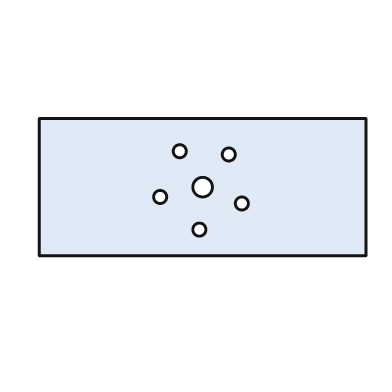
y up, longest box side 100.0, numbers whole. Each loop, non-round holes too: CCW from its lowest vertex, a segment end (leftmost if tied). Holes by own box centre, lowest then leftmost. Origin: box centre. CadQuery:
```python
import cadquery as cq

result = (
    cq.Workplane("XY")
    .moveTo(-50.0, -21.0)
    .lineTo(50.0, -21.0)
    .lineTo(50.0, 21.0)
    .lineTo(-50.0, 21.0)
    .close()
    .moveTo(-1.0, -13.0)
    .circle(2.0)
    .moveTo(12.0, -5.0)
    .circle(2.0)
    .moveTo(-13.0, -3.0)
    .circle(2.0)
    .moveTo(0.0, 0.0)
    .circle(3.0)
    .moveTo(8.0, 10.0)
    .circle(2.0)
    .moveTo(-7.0, 11.0)
    .circle(2.0)
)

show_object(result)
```